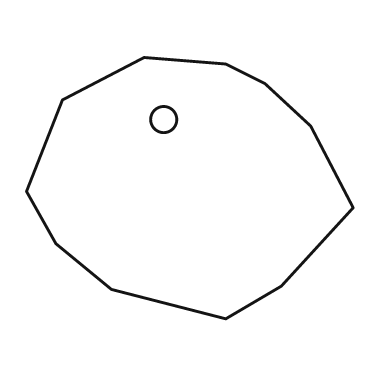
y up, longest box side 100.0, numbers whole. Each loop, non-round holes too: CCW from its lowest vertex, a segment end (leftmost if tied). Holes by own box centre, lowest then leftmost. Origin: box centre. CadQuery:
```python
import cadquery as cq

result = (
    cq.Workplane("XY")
    .moveTo(11.0, -40.0)
    .lineTo(28.0, -30.0)
    .lineTo(50.0, -6.0)
    .lineTo(37.0, 19.0)
    .lineTo(23.0, 32.0)
    .lineTo(11.0, 38.0)
    .lineTo(-14.0, 40.0)
    .lineTo(-39.0, 27.0)
    .lineTo(-50.0, -1.0)
    .lineTo(-41.0, -17.0)
    .lineTo(-24.0, -31.0)
    .close()
    .moveTo(-8.0, 21.0)
    .circle(4.0)
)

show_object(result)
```